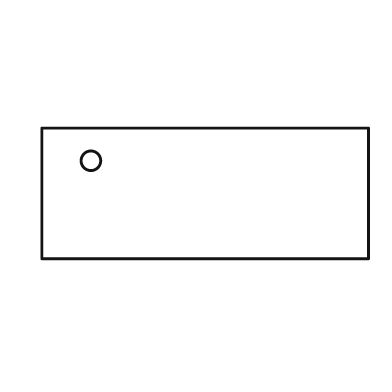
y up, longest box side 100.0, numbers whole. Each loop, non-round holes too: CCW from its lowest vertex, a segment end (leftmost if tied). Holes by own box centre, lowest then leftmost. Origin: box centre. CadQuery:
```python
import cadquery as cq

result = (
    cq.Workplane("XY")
    .moveTo(-50.0, -20.0)
    .lineTo(50.0, -20.0)
    .lineTo(50.0, 20.0)
    .lineTo(-50.0, 20.0)
    .close()
    .moveTo(-35.0, 10.0)
    .circle(3.0)
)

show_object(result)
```